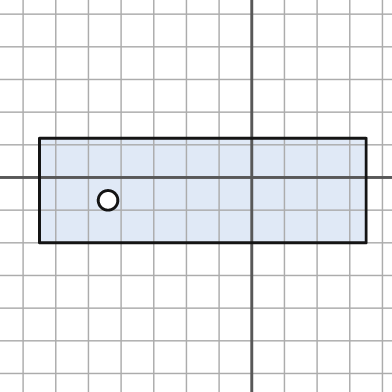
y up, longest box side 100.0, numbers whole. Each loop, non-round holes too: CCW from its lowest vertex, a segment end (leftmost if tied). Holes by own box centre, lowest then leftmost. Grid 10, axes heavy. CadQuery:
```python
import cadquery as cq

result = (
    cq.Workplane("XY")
    .moveTo(-65.0, -20.0)
    .lineTo(35.0, -20.0)
    .lineTo(35.0, 12.0)
    .lineTo(-65.0, 12.0)
    .close()
    .moveTo(-44.0, -7.0)
    .circle(3.0)
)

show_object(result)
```